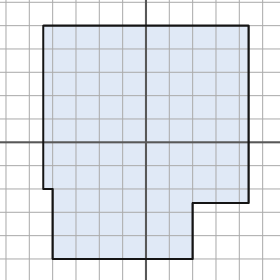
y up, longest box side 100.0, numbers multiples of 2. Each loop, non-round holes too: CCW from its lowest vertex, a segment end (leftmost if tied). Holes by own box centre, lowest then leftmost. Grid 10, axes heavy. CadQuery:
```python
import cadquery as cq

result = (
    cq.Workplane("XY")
    .moveTo(-40.0, -50.0)
    .lineTo(20.0, -50.0)
    .lineTo(20.0, -26.0)
    .lineTo(44.0, -26.0)
    .lineTo(44.0, 50.0)
    .lineTo(-44.0, 50.0)
    .lineTo(-44.0, -20.0)
    .lineTo(-40.0, -20.0)
    .close()
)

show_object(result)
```